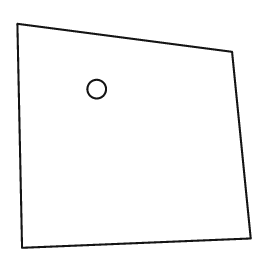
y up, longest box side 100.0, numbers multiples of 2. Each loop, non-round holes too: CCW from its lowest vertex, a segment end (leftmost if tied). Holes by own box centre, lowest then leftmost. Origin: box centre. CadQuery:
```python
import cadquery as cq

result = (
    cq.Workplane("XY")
    .moveTo(-48.0, -48.0)
    .lineTo(50.0, -44.0)
    .lineTo(42.0, 36.0)
    .lineTo(-50.0, 48.0)
    .close()
    .moveTo(-16.0, 20.0)
    .circle(4.0)
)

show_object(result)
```